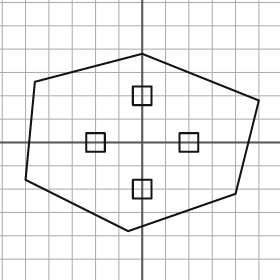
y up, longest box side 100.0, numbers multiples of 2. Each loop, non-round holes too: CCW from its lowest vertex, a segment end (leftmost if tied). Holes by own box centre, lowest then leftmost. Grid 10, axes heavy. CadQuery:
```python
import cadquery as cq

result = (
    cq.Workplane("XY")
    .moveTo(-6.0, -38.0)
    .lineTo(40.0, -22.0)
    .lineTo(50.0, 18.0)
    .lineTo(0.0, 38.0)
    .lineTo(-46.0, 26.0)
    .lineTo(-50.0, -16.0)
    .close()
    .moveTo(-4.0, -24.0)
    .lineTo(4.0, -24.0)
    .lineTo(4.0, -16.0)
    .lineTo(-4.0, -16.0)
    .close()
    .moveTo(-24.0, -4.0)
    .lineTo(-16.0, -4.0)
    .lineTo(-16.0, 4.0)
    .lineTo(-24.0, 4.0)
    .close()
    .moveTo(16.0, -4.0)
    .lineTo(24.0, -4.0)
    .lineTo(24.0, 4.0)
    .lineTo(16.0, 4.0)
    .close()
    .moveTo(-4.0, 16.0)
    .lineTo(4.0, 16.0)
    .lineTo(4.0, 24.0)
    .lineTo(-4.0, 24.0)
    .close()
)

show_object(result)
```